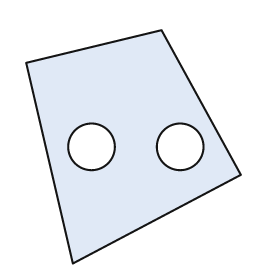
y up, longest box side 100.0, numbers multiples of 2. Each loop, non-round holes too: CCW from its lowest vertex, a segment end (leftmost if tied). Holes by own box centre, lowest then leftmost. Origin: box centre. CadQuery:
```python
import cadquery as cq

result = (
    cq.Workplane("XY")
    .moveTo(-26.0, -50.0)
    .lineTo(46.0, -12.0)
    .lineTo(12.0, 50.0)
    .lineTo(-46.0, 36.0)
    .close()
    .moveTo(-18.0, 0.0)
    .circle(10.0)
    .moveTo(20.0, 0.0)
    .circle(10.0)
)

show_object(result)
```